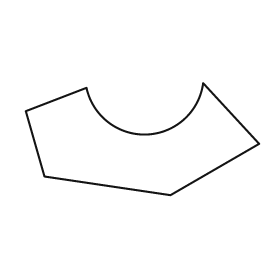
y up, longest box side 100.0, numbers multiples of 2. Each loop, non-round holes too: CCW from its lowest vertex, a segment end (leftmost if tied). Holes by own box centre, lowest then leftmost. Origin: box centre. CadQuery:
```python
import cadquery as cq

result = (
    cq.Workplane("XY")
    .moveTo(12.0, -24.0)
    .lineTo(50.0, -2.0)
    .lineTo(26.0, 24.0)
    .threePointArc((2.0, 2.0), (-24.0, 22.0))
    .lineTo(-50.0, 12.0)
    .lineTo(-42.0, -16.0)
    .close()
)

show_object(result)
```